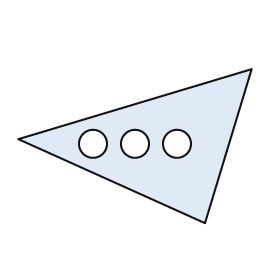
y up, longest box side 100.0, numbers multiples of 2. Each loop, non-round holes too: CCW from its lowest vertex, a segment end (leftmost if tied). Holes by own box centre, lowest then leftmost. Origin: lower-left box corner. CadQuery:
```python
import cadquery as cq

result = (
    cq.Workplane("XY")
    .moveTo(80.0, 0.0)
    .lineTo(100.0, 66.0)
    .lineTo(0.0, 36.0)
    .close()
    .moveTo(32.0, 34.0)
    .circle(6.0)
    .moveTo(50.0, 34.0)
    .circle(6.0)
    .moveTo(68.0, 34.0)
    .circle(6.0)
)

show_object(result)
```